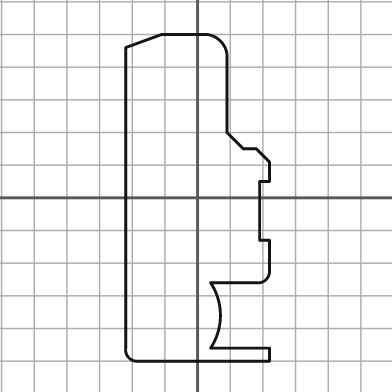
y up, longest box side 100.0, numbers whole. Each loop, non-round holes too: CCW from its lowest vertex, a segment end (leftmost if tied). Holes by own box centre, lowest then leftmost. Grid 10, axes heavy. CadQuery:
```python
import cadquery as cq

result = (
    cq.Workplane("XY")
    .moveTo(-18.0, -50.0)
    .lineTo(22.0, -50.0)
    .lineTo(22.0, -46.0)
    .lineTo(4.0, -46.0)
    .threePointArc((7.0, -36.0), (4.0, -26.0))
    .lineTo(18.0, -26.0)
    .threePointArc((21.0, -25.0), (22.0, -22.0))
    .lineTo(22.0, -13.0)
    .lineTo(19.0, -13.0)
    .lineTo(19.0, 5.0)
    .lineTo(22.0, 5.0)
    .lineTo(22.0, 11.0)
    .lineTo(18.0, 15.0)
    .lineTo(14.0, 15.0)
    .lineTo(9.0, 20.0)
    .lineTo(9.0, 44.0)
    .threePointArc((7.0, 48.0), (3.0, 50.0))
    .lineTo(-11.0, 50.0)
    .lineTo(-22.0, 46.0)
    .lineTo(-22.0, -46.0)
    .threePointArc((-21.0, -49.0), (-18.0, -50.0))
    .close()
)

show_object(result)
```